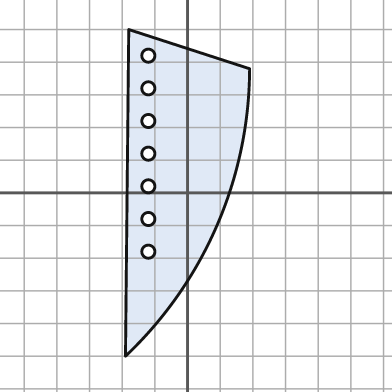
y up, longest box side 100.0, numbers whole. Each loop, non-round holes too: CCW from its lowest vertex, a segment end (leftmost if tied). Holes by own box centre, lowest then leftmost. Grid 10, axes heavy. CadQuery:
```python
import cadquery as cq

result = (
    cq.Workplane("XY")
    .moveTo(-19.0, -50.0)
    .threePointArc((9.0, -10.0), (19.0, 38.0))
    .lineTo(-18.0, 50.0)
    .close()
    .moveTo(-12.0, -18.0)
    .circle(2.0)
    .moveTo(-12.0, -8.0)
    .circle(2.0)
    .moveTo(-12.0, 2.0)
    .circle(2.0)
    .moveTo(-12.0, 12.0)
    .circle(2.0)
    .moveTo(-12.0, 22.0)
    .circle(2.0)
    .moveTo(-12.0, 32.0)
    .circle(2.0)
    .moveTo(-12.0, 42.0)
    .circle(2.0)
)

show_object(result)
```